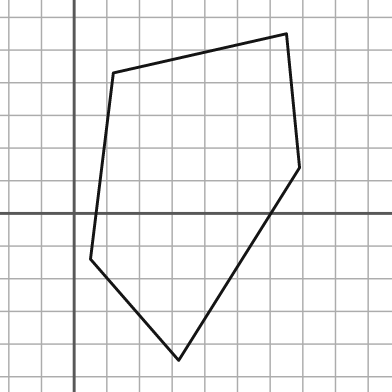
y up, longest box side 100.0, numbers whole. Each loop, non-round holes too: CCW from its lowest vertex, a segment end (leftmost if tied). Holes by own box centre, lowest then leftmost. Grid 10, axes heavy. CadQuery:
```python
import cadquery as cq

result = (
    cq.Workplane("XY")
    .moveTo(32.0, -45.0)
    .lineTo(69.0, 14.0)
    .lineTo(65.0, 55.0)
    .lineTo(12.0, 43.0)
    .lineTo(5.0, -14.0)
    .close()
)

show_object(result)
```